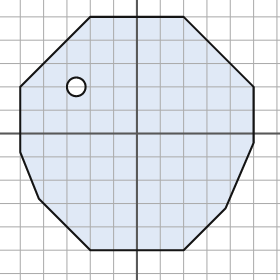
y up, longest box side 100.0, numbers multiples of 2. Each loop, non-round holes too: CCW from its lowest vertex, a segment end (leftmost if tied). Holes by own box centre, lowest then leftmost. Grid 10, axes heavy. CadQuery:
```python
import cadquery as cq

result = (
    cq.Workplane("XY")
    .moveTo(-20.0, -50.0)
    .lineTo(20.0, -50.0)
    .lineTo(38.0, -32.0)
    .lineTo(50.0, -4.0)
    .lineTo(50.0, 20.0)
    .lineTo(20.0, 50.0)
    .lineTo(-20.0, 50.0)
    .lineTo(-50.0, 20.0)
    .lineTo(-50.0, -8.0)
    .lineTo(-42.0, -28.0)
    .close()
    .moveTo(-26.0, 20.0)
    .circle(4.0)
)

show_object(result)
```